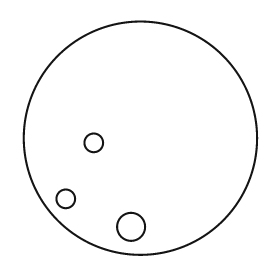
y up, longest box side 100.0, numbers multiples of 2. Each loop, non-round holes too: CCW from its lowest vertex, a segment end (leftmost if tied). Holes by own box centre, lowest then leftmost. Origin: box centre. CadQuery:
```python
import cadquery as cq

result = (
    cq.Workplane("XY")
    .moveTo(0.0, 0.0)
    .circle(50.0)
    .moveTo(-4.0, -38.0)
    .circle(6.0)
    .moveTo(-32.0, -26.0)
    .circle(4.0)
    .moveTo(-20.0, -2.0)
    .circle(4.0)
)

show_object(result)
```